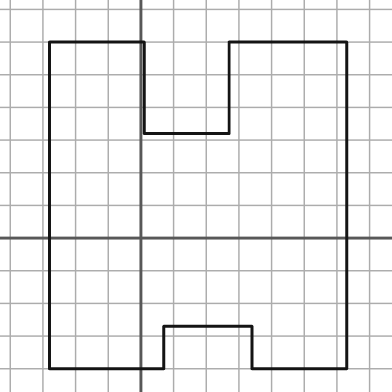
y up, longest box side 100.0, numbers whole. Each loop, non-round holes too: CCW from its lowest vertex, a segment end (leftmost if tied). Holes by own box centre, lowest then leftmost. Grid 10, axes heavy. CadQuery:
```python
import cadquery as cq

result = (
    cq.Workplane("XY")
    .moveTo(-28.0, -40.0)
    .lineTo(7.0, -40.0)
    .lineTo(7.0, -27.0)
    .lineTo(34.0, -27.0)
    .lineTo(34.0, -40.0)
    .lineTo(63.0, -40.0)
    .lineTo(63.0, 60.0)
    .lineTo(27.0, 60.0)
    .lineTo(27.0, 32.0)
    .lineTo(1.0, 32.0)
    .lineTo(1.0, 60.0)
    .lineTo(-28.0, 60.0)
    .close()
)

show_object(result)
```